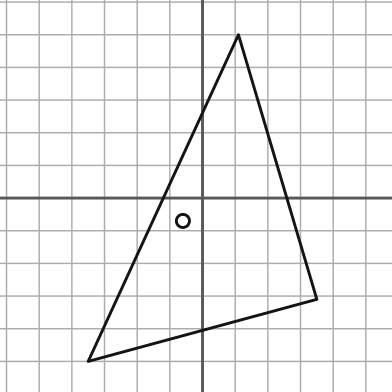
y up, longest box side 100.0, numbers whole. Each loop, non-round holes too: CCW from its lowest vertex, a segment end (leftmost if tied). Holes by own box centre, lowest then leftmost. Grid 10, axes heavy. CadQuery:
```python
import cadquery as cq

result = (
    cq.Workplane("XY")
    .moveTo(-35.0, -50.0)
    .lineTo(35.0, -31.0)
    .lineTo(11.0, 50.0)
    .close()
    .moveTo(-6.0, -7.0)
    .circle(2.0)
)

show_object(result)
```